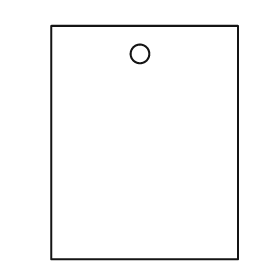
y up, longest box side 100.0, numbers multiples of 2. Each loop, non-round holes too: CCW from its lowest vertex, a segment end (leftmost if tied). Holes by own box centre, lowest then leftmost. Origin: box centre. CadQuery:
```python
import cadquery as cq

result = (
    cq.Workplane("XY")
    .moveTo(-40.0, -50.0)
    .lineTo(40.0, -50.0)
    .lineTo(40.0, 50.0)
    .lineTo(-40.0, 50.0)
    .close()
    .moveTo(-2.0, 38.0)
    .circle(4.0)
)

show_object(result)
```